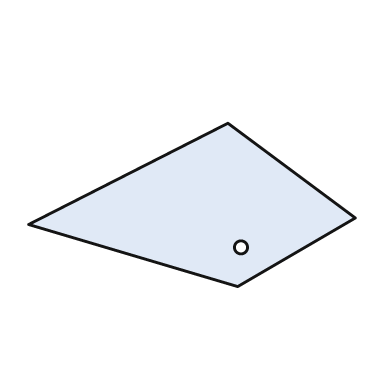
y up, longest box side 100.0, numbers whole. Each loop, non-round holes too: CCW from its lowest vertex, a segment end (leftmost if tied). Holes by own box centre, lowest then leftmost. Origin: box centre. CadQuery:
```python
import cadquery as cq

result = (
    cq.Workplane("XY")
    .moveTo(14.0, -25.0)
    .lineTo(50.0, -4.0)
    .lineTo(11.0, 25.0)
    .lineTo(-50.0, -6.0)
    .close()
    .moveTo(15.0, -13.0)
    .circle(2.0)
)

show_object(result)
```